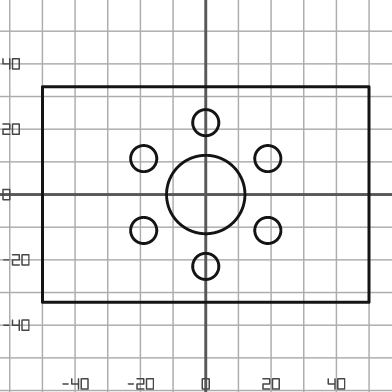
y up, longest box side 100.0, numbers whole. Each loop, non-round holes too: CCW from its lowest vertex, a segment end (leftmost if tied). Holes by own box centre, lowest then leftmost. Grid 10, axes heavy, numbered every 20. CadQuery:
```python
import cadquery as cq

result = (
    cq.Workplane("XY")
    .moveTo(-50.0, -33.0)
    .lineTo(50.0, -33.0)
    .lineTo(50.0, 33.0)
    .lineTo(-50.0, 33.0)
    .close()
    .moveTo(0.0, -22.0)
    .circle(4.0)
    .moveTo(-19.0, -11.0)
    .circle(4.0)
    .moveTo(19.0, -11.0)
    .circle(4.0)
    .moveTo(0.0, 0.0)
    .circle(12.0)
    .moveTo(-19.0, 11.0)
    .circle(4.0)
    .moveTo(19.0, 11.0)
    .circle(4.0)
    .moveTo(0.0, 22.0)
    .circle(4.0)
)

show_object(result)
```